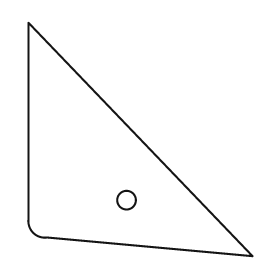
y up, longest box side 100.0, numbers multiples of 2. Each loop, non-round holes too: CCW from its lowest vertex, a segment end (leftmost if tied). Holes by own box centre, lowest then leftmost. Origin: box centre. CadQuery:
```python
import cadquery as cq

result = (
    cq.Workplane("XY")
    .moveTo(48.0, -50.0)
    .lineTo(-48.0, 50.0)
    .lineTo(-48.0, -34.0)
    .threePointArc((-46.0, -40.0), (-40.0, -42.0))
    .close()
    .moveTo(-6.0, -26.0)
    .circle(4.0)
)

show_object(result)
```